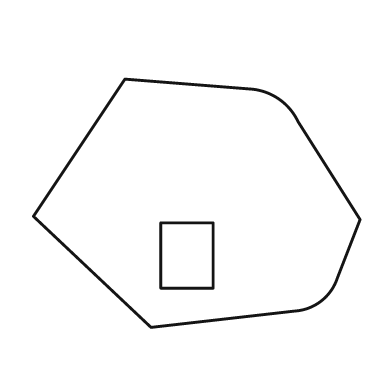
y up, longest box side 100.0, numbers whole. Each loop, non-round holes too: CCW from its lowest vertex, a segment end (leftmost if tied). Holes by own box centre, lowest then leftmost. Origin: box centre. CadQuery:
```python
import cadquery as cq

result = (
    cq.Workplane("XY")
    .moveTo(-14.0, -38.0)
    .lineTo(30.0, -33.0)
    .threePointArc((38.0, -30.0), (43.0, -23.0))
    .lineTo(50.0, -5.0)
    .lineTo(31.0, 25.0)
    .threePointArc((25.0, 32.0), (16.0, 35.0))
    .lineTo(-22.0, 38.0)
    .lineTo(-50.0, -4.0)
    .close()
    .moveTo(-11.0, -26.0)
    .lineTo(5.0, -26.0)
    .lineTo(5.0, -6.0)
    .lineTo(-11.0, -6.0)
    .close()
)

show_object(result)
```